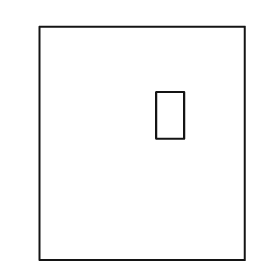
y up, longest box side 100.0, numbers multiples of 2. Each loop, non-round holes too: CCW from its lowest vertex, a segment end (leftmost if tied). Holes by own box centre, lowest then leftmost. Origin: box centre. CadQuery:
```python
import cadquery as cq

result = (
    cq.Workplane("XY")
    .moveTo(-44.0, -50.0)
    .lineTo(44.0, -50.0)
    .lineTo(44.0, 50.0)
    .lineTo(-44.0, 50.0)
    .close()
    .moveTo(6.0, 2.0)
    .lineTo(18.0, 2.0)
    .lineTo(18.0, 22.0)
    .lineTo(6.0, 22.0)
    .close()
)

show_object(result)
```